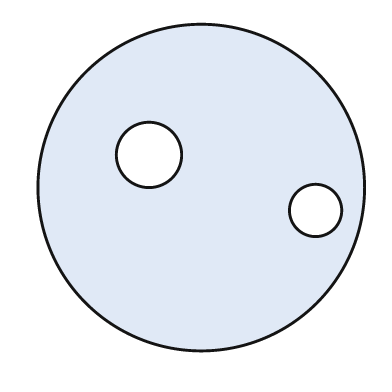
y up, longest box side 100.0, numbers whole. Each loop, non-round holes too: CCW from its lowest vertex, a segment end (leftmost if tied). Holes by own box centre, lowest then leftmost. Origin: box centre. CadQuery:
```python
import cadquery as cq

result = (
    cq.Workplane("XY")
    .moveTo(0.0, 0.0)
    .circle(50.0)
    .moveTo(35.0, -7.0)
    .circle(8.0)
    .moveTo(-16.0, 10.0)
    .circle(10.0)
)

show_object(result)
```